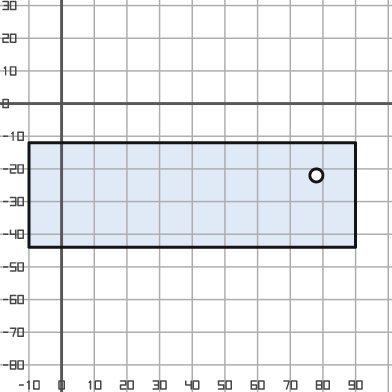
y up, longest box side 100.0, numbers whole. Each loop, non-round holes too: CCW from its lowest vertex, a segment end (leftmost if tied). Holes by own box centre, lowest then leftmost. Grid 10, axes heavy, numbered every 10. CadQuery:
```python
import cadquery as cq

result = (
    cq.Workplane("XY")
    .moveTo(-10.0, -44.0)
    .lineTo(90.0, -44.0)
    .lineTo(90.0, -12.0)
    .lineTo(-10.0, -12.0)
    .close()
    .moveTo(78.0, -22.0)
    .circle(2.0)
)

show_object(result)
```